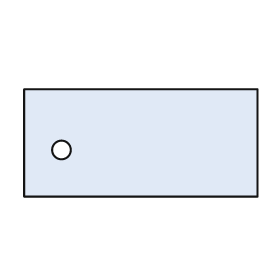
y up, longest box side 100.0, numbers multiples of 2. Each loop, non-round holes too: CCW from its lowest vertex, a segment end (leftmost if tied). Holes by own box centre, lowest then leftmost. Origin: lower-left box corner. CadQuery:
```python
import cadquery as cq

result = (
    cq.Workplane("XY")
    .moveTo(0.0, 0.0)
    .lineTo(100.0, 0.0)
    .lineTo(100.0, 46.0)
    .lineTo(0.0, 46.0)
    .close()
    .moveTo(16.0, 20.0)
    .circle(4.0)
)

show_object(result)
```